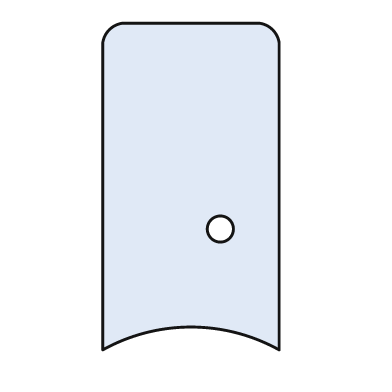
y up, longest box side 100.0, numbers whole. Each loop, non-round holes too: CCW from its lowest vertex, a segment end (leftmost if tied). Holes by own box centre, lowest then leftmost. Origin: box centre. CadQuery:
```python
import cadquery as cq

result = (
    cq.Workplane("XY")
    .moveTo(-27.0, -50.0)
    .threePointArc((0.0, -43.0), (27.0, -50.0))
    .lineTo(27.0, 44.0)
    .threePointArc((25.0, 48.0), (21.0, 50.0))
    .lineTo(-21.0, 50.0)
    .threePointArc((-25.0, 48.0), (-27.0, 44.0))
    .close()
    .moveTo(9.0, -13.0)
    .circle(4.0)
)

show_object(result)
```